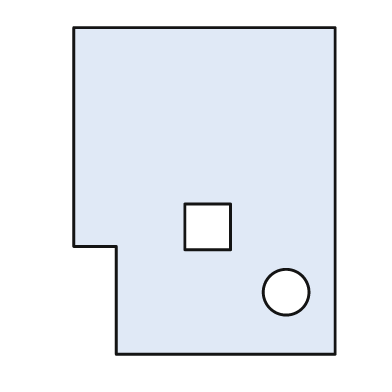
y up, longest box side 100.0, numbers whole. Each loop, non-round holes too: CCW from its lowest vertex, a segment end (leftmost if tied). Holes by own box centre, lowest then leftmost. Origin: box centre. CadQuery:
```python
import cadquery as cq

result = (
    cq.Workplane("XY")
    .moveTo(-27.0, -50.0)
    .lineTo(40.0, -50.0)
    .lineTo(40.0, 50.0)
    .lineTo(-40.0, 50.0)
    .lineTo(-40.0, -17.0)
    .lineTo(-27.0, -17.0)
    .close()
    .moveTo(25.0, -31.0)
    .circle(7.0)
    .moveTo(-6.0, -18.0)
    .lineTo(8.0, -18.0)
    .lineTo(8.0, -4.0)
    .lineTo(-6.0, -4.0)
    .close()
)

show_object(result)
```